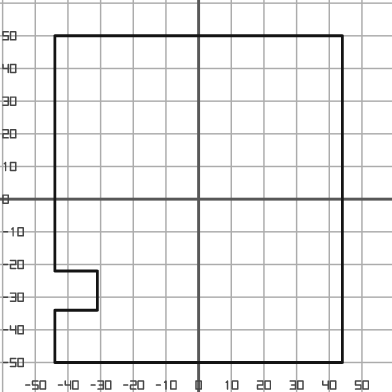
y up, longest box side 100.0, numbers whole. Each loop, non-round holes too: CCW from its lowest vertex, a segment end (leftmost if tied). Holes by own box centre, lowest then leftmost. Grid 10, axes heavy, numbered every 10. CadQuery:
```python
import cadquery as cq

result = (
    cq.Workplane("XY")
    .moveTo(-44.0, -50.0)
    .lineTo(44.0, -50.0)
    .lineTo(44.0, 50.0)
    .lineTo(-44.0, 50.0)
    .lineTo(-44.0, -22.0)
    .lineTo(-31.0, -22.0)
    .lineTo(-31.0, -34.0)
    .lineTo(-44.0, -34.0)
    .close()
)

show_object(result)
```